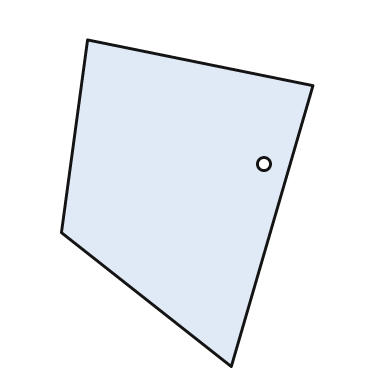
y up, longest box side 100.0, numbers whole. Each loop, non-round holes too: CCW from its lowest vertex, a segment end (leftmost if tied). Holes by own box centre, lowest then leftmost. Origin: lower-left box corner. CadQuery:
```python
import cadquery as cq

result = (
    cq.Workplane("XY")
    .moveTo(52.0, 0.0)
    .lineTo(77.0, 86.0)
    .lineTo(8.0, 100.0)
    .lineTo(0.0, 41.0)
    .close()
    .moveTo(62.0, 62.0)
    .circle(2.0)
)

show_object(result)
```